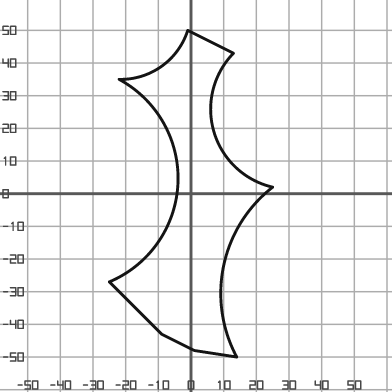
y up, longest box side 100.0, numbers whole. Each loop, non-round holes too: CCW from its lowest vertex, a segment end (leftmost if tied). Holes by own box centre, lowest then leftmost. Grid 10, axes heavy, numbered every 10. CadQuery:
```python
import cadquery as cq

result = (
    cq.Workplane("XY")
    .moveTo(14.0, -50.0)
    .threePointArc((10.0, -22.0), (25.0, 2.0))
    .threePointArc((7.0, 19.0), (13.0, 43.0))
    .lineTo(-1.0, 50.0)
    .threePointArc((-9.0, 39.0), (-22.0, 35.0))
    .threePointArc((-4.0, 3.0), (-25.0, -27.0))
    .lineTo(-9.0, -43.0)
    .lineTo(1.0, -48.0)
    .close()
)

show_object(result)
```